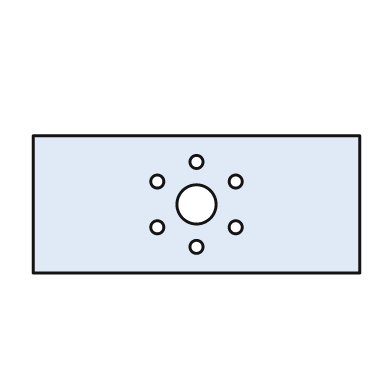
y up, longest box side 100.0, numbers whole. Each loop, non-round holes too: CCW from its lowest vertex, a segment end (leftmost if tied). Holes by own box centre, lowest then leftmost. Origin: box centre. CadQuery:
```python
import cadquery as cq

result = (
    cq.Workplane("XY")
    .moveTo(-50.0, -21.0)
    .lineTo(50.0, -21.0)
    .lineTo(50.0, 21.0)
    .lineTo(-50.0, 21.0)
    .close()
    .moveTo(0.0, -13.0)
    .circle(2.0)
    .moveTo(-12.0, -7.0)
    .circle(2.0)
    .moveTo(12.0, -7.0)
    .circle(2.0)
    .moveTo(0.0, 0.0)
    .circle(6.0)
    .moveTo(-12.0, 7.0)
    .circle(2.0)
    .moveTo(12.0, 7.0)
    .circle(2.0)
    .moveTo(0.0, 13.0)
    .circle(2.0)
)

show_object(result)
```